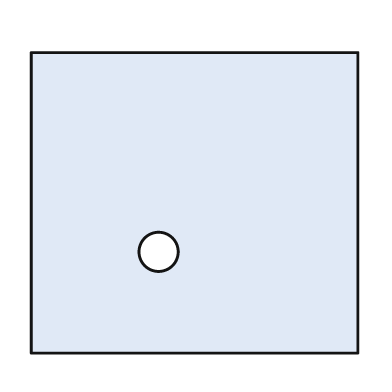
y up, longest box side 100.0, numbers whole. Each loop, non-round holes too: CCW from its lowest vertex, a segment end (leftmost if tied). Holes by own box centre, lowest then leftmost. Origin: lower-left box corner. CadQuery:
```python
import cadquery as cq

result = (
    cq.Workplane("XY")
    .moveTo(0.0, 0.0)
    .lineTo(100.0, 0.0)
    .lineTo(100.0, 92.0)
    .lineTo(0.0, 92.0)
    .close()
    .moveTo(39.0, 31.0)
    .circle(6.0)
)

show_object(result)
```